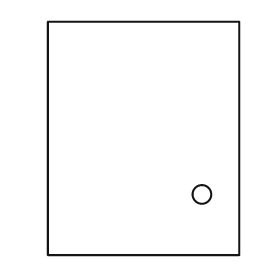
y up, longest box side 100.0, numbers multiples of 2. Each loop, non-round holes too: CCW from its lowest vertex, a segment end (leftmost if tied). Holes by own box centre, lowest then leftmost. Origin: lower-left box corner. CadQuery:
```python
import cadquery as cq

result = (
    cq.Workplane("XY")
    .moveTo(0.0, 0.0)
    .lineTo(82.0, 0.0)
    .lineTo(82.0, 100.0)
    .lineTo(0.0, 100.0)
    .close()
    .moveTo(66.0, 26.0)
    .circle(4.0)
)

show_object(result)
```